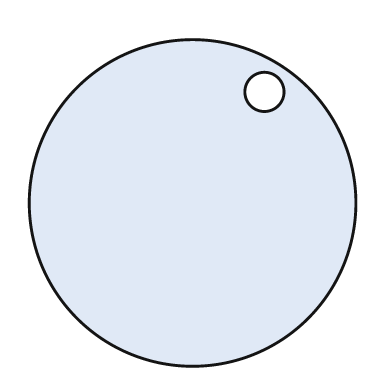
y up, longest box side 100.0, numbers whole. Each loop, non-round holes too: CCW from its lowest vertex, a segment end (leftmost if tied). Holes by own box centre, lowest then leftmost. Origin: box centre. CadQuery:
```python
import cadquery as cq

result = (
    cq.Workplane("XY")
    .moveTo(0.0, 0.0)
    .circle(50.0)
    .moveTo(22.0, 34.0)
    .circle(6.0)
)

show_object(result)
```